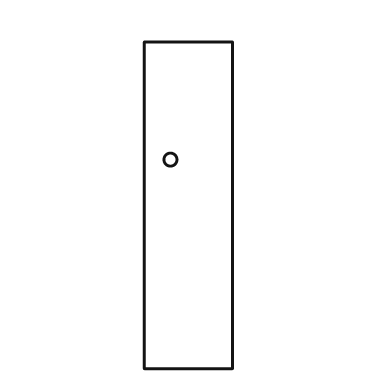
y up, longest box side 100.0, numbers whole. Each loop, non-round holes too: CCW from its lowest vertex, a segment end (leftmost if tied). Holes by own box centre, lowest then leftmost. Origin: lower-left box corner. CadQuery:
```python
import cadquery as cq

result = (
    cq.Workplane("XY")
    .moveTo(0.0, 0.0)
    .lineTo(27.0, 0.0)
    .lineTo(27.0, 100.0)
    .lineTo(0.0, 100.0)
    .close()
    .moveTo(8.0, 64.0)
    .circle(2.0)
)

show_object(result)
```